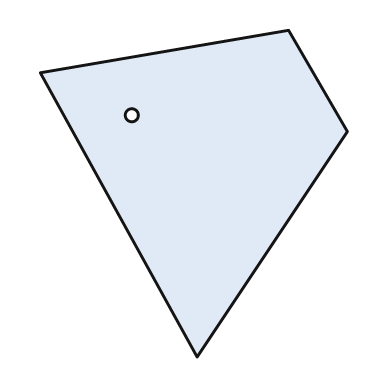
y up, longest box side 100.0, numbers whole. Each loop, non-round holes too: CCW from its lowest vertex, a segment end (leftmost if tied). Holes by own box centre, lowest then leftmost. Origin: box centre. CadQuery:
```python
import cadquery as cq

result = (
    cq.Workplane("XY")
    .moveTo(1.0, -50.0)
    .lineTo(47.0, 19.0)
    .lineTo(29.0, 50.0)
    .lineTo(-47.0, 37.0)
    .close()
    .moveTo(-19.0, 24.0)
    .circle(2.0)
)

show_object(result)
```